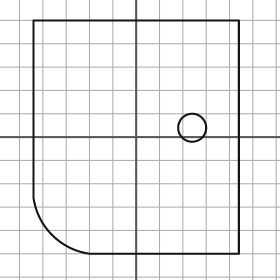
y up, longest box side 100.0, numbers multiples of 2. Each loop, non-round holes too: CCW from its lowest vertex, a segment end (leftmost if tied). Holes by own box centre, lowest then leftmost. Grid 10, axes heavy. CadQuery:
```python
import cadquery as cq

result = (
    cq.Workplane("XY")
    .moveTo(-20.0, -50.0)
    .lineTo(44.0, -50.0)
    .lineTo(44.0, 50.0)
    .lineTo(-44.0, 50.0)
    .lineTo(-44.0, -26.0)
    .threePointArc((-36.0, -42.0), (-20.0, -50.0))
    .close()
    .moveTo(24.0, 4.0)
    .circle(6.0)
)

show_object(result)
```